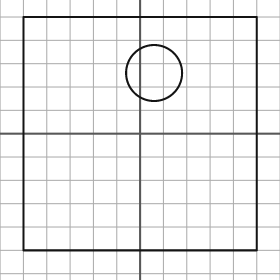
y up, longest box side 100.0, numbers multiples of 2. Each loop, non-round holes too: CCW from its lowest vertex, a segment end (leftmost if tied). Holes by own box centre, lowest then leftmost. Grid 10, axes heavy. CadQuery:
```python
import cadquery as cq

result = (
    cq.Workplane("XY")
    .moveTo(-50.0, -50.0)
    .lineTo(50.0, -50.0)
    .lineTo(50.0, 50.0)
    .lineTo(-50.0, 50.0)
    .close()
    .moveTo(6.0, 26.0)
    .circle(12.0)
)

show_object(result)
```